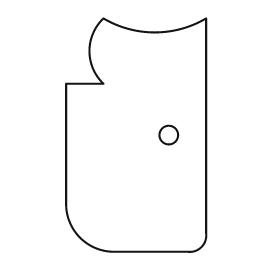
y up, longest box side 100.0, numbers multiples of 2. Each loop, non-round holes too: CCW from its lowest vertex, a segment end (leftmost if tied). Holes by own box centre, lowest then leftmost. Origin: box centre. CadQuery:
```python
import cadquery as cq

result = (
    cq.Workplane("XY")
    .moveTo(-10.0, -50.0)
    .lineTo(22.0, -50.0)
    .threePointArc((28.0, -48.0), (30.0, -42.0))
    .lineTo(30.0, 50.0)
    .threePointArc((8.0, 44.0), (-14.0, 50.0))
    .threePointArc((-20.0, 36.0), (-14.0, 22.0))
    .lineTo(-30.0, 22.0)
    .lineTo(-30.0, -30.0)
    .threePointArc((-24.0, -44.0), (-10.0, -50.0))
    .close()
    .moveTo(14.0, 0.0)
    .circle(4.0)
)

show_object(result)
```